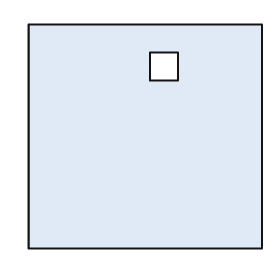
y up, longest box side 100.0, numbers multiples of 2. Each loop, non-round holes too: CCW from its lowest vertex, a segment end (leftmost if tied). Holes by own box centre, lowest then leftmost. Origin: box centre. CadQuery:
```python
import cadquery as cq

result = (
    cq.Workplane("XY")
    .moveTo(-50.0, -48.0)
    .lineTo(50.0, -48.0)
    .lineTo(50.0, 48.0)
    .lineTo(-50.0, 48.0)
    .close()
    .moveTo(2.0, 24.0)
    .lineTo(14.0, 24.0)
    .lineTo(14.0, 36.0)
    .lineTo(2.0, 36.0)
    .close()
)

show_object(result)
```